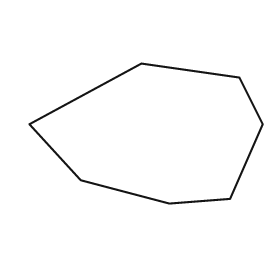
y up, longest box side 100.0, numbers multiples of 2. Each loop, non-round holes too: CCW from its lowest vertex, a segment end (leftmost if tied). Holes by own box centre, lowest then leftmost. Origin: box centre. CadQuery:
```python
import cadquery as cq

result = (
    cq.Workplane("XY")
    .moveTo(10.0, -30.0)
    .lineTo(36.0, -28.0)
    .lineTo(50.0, 4.0)
    .lineTo(40.0, 24.0)
    .lineTo(-2.0, 30.0)
    .lineTo(-50.0, 4.0)
    .lineTo(-28.0, -20.0)
    .close()
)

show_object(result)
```